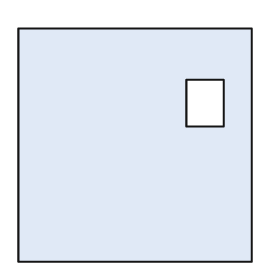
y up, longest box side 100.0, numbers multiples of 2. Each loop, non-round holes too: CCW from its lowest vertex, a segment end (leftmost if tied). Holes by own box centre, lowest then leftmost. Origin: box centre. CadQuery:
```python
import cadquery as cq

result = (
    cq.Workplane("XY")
    .moveTo(-50.0, -50.0)
    .lineTo(50.0, -50.0)
    .lineTo(50.0, 50.0)
    .lineTo(-50.0, 50.0)
    .close()
    .moveTo(22.0, 8.0)
    .lineTo(38.0, 8.0)
    .lineTo(38.0, 28.0)
    .lineTo(22.0, 28.0)
    .close()
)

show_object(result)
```